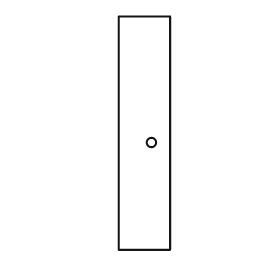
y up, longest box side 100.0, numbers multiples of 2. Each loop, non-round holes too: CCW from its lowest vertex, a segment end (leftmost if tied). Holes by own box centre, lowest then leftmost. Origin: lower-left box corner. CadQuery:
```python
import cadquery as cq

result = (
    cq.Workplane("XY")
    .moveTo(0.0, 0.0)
    .lineTo(22.0, 0.0)
    .lineTo(22.0, 100.0)
    .lineTo(0.0, 100.0)
    .close()
    .moveTo(14.0, 46.0)
    .circle(2.0)
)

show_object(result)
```